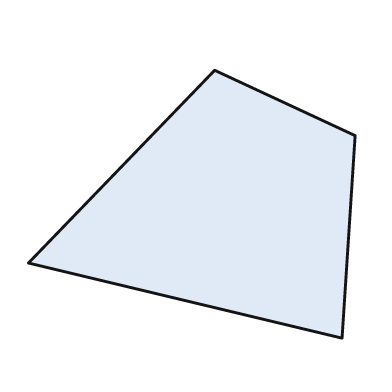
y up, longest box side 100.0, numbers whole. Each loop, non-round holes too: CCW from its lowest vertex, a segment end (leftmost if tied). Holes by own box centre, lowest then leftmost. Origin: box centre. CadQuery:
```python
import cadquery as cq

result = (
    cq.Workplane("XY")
    .moveTo(46.0, -41.0)
    .lineTo(50.0, 21.0)
    .lineTo(7.0, 41.0)
    .lineTo(-50.0, -18.0)
    .close()
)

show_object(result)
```